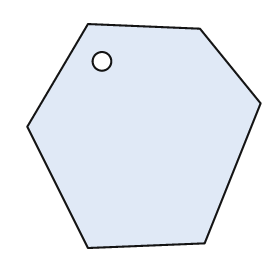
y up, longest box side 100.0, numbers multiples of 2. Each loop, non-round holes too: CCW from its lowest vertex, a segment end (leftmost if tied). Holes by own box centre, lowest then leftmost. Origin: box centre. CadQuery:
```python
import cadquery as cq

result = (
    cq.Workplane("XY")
    .moveTo(-24.0, -48.0)
    .lineTo(26.0, -46.0)
    .lineTo(50.0, 14.0)
    .lineTo(24.0, 46.0)
    .lineTo(-24.0, 48.0)
    .lineTo(-50.0, 4.0)
    .close()
    .moveTo(-18.0, 32.0)
    .circle(4.0)
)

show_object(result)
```